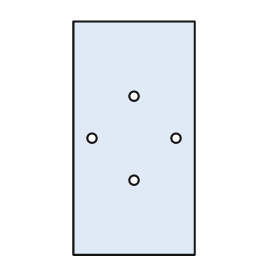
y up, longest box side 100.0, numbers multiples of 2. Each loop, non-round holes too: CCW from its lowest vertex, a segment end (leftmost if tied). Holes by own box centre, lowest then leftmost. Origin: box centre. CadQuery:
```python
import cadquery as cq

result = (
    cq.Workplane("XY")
    .moveTo(-26.0, -50.0)
    .lineTo(26.0, -50.0)
    .lineTo(26.0, 50.0)
    .lineTo(-26.0, 50.0)
    .close()
    .moveTo(0.0, -18.0)
    .circle(2.0)
    .moveTo(-18.0, 0.0)
    .circle(2.0)
    .moveTo(18.0, 0.0)
    .circle(2.0)
    .moveTo(0.0, 18.0)
    .circle(2.0)
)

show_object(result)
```